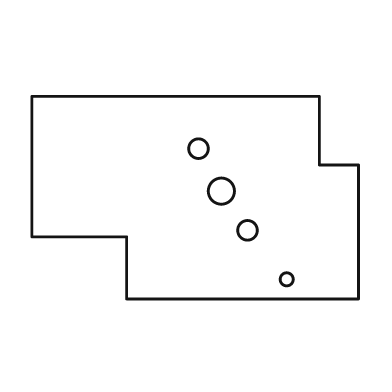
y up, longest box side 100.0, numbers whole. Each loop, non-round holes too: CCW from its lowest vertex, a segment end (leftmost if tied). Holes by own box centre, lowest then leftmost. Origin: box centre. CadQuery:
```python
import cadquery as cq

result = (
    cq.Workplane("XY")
    .moveTo(-21.0, -31.0)
    .lineTo(50.0, -31.0)
    .lineTo(50.0, 10.0)
    .lineTo(38.0, 10.0)
    .lineTo(38.0, 31.0)
    .lineTo(-50.0, 31.0)
    .lineTo(-50.0, -12.0)
    .lineTo(-21.0, -12.0)
    .close()
    .moveTo(28.0, -25.0)
    .circle(2.0)
    .moveTo(16.0, -10.0)
    .circle(3.0)
    .moveTo(8.0, 2.0)
    .circle(4.0)
    .moveTo(1.0, 15.0)
    .circle(3.0)
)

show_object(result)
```